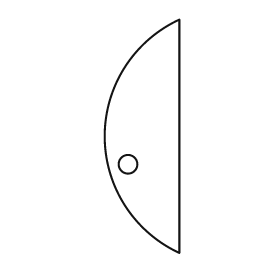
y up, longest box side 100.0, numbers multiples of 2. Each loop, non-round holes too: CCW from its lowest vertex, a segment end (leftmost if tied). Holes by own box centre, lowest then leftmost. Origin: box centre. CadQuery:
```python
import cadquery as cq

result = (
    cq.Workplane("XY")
    .moveTo(16.0, -50.0)
    .lineTo(16.0, 50.0)
    .threePointArc((-16.0, 0.0), (16.0, -50.0))
    .close()
    .moveTo(-6.0, -12.0)
    .circle(4.0)
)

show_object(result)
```